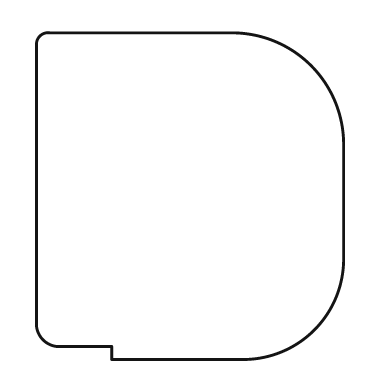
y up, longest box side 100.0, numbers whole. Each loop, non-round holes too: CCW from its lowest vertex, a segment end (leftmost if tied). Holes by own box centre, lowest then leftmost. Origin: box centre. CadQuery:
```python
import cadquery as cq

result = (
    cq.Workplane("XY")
    .moveTo(-24.0, -50.0)
    .lineTo(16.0, -50.0)
    .threePointArc((38.0, -41.0), (47.0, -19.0))
    .lineTo(47.0, 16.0)
    .threePointArc((37.0, 40.0), (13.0, 50.0))
    .lineTo(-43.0, 50.0)
    .threePointArc((-46.0, 49.0), (-47.0, 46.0))
    .lineTo(-47.0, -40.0)
    .threePointArc((-45.0, -44.0), (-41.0, -46.0))
    .lineTo(-24.0, -46.0)
    .close()
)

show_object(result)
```